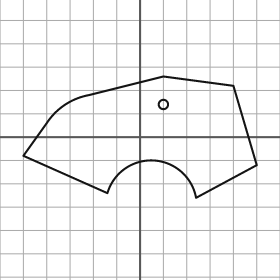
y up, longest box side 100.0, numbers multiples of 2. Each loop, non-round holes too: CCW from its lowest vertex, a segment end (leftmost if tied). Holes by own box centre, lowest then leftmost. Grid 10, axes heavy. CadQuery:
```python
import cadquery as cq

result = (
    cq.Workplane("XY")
    .moveTo(24.0, -26.0)
    .lineTo(50.0, -12.0)
    .lineTo(40.0, 22.0)
    .lineTo(10.0, 26.0)
    .lineTo(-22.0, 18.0)
    .threePointArc((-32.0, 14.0), (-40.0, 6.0))
    .lineTo(-50.0, -8.0)
    .lineTo(-14.0, -24.0)
    .threePointArc((6.0, -10.0), (24.0, -26.0))
    .close()
    .moveTo(10.0, 14.0)
    .circle(2.0)
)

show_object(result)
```